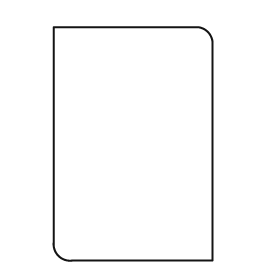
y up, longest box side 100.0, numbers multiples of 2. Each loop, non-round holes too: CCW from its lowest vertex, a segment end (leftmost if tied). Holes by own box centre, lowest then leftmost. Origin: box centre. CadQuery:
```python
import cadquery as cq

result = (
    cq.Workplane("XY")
    .moveTo(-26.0, -50.0)
    .lineTo(34.0, -50.0)
    .lineTo(34.0, 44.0)
    .threePointArc((32.0, 48.0), (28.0, 50.0))
    .lineTo(-34.0, 50.0)
    .lineTo(-34.0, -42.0)
    .threePointArc((-32.0, -48.0), (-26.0, -50.0))
    .close()
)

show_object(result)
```